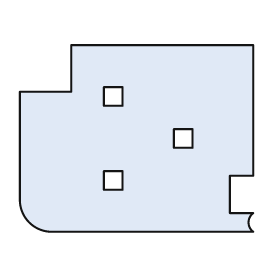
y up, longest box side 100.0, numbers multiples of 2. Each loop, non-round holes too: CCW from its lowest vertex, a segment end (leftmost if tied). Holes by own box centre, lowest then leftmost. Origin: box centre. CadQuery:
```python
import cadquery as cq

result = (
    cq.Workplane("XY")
    .moveTo(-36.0, -40.0)
    .lineTo(50.0, -40.0)
    .threePointArc((48.0, -36.0), (50.0, -32.0))
    .lineTo(40.0, -32.0)
    .lineTo(40.0, -16.0)
    .lineTo(50.0, -16.0)
    .lineTo(50.0, 40.0)
    .lineTo(-28.0, 40.0)
    .lineTo(-28.0, 20.0)
    .lineTo(-50.0, 20.0)
    .lineTo(-50.0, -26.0)
    .threePointArc((-46.0, -36.0), (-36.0, -40.0))
    .close()
    .moveTo(-14.0, -22.0)
    .lineTo(-6.0, -22.0)
    .lineTo(-6.0, -14.0)
    .lineTo(-14.0, -14.0)
    .close()
    .moveTo(16.0, -4.0)
    .lineTo(24.0, -4.0)
    .lineTo(24.0, 4.0)
    .lineTo(16.0, 4.0)
    .close()
    .moveTo(-14.0, 14.0)
    .lineTo(-6.0, 14.0)
    .lineTo(-6.0, 22.0)
    .lineTo(-14.0, 22.0)
    .close()
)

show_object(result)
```